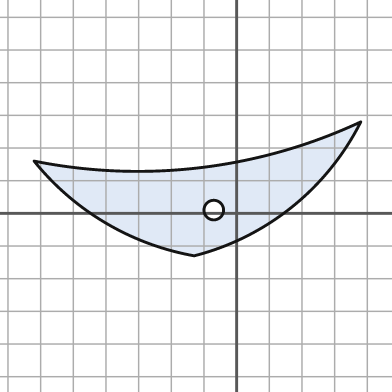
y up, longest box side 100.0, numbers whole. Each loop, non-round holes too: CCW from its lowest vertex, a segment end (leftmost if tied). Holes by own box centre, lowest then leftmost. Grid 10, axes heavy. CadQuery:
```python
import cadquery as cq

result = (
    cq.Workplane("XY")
    .moveTo(-13.0, -13.0)
    .threePointArc((17.0, 2.0), (38.0, 28.0))
    .threePointArc((-11.0, 14.0), (-62.0, 16.0))
    .threePointArc((-40.0, -3.0), (-13.0, -13.0))
    .close()
    .moveTo(-7.0, 1.0)
    .circle(3.0)
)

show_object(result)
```